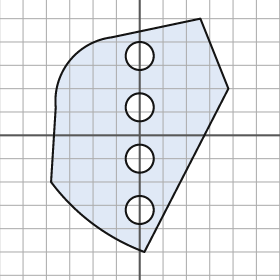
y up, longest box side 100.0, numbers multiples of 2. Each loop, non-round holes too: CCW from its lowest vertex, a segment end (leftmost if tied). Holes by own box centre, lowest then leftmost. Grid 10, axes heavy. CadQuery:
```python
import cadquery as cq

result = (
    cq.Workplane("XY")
    .moveTo(2.0, -50.0)
    .lineTo(38.0, 20.0)
    .lineTo(26.0, 50.0)
    .lineTo(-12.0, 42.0)
    .threePointArc((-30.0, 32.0), (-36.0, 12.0))
    .lineTo(-38.0, -20.0)
    .threePointArc((-20.0, -38.0), (2.0, -50.0))
    .close()
    .moveTo(0.0, -32.0)
    .circle(6.0)
    .moveTo(0.0, -10.0)
    .circle(6.0)
    .moveTo(0.0, 12.0)
    .circle(6.0)
    .moveTo(0.0, 34.0)
    .circle(6.0)
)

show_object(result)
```